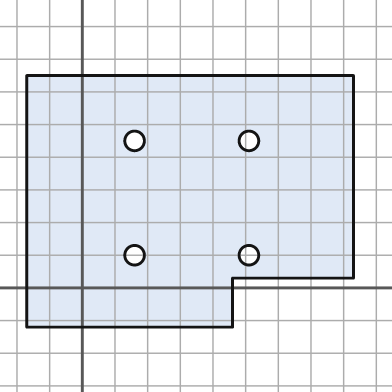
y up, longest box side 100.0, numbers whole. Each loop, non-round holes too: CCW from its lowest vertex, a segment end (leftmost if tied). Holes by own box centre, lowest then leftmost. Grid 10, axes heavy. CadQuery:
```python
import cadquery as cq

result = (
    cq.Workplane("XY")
    .moveTo(-17.0, -12.0)
    .lineTo(46.0, -12.0)
    .lineTo(46.0, 3.0)
    .lineTo(83.0, 3.0)
    .lineTo(83.0, 65.0)
    .lineTo(-17.0, 65.0)
    .close()
    .moveTo(16.0, 10.0)
    .circle(3.0)
    .moveTo(51.0, 10.0)
    .circle(3.0)
    .moveTo(16.0, 45.0)
    .circle(3.0)
    .moveTo(51.0, 45.0)
    .circle(3.0)
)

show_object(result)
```